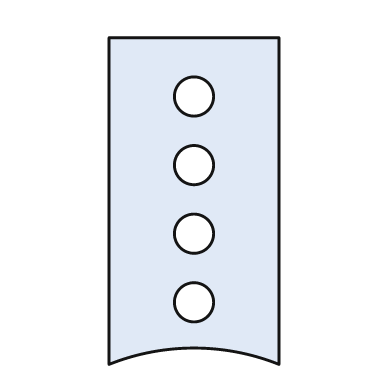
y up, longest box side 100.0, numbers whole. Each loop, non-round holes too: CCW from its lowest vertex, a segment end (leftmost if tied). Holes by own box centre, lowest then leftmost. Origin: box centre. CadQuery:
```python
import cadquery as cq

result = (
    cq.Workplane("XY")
    .moveTo(-26.0, -50.0)
    .threePointArc((0.0, -45.0), (26.0, -50.0))
    .lineTo(26.0, 50.0)
    .lineTo(-26.0, 50.0)
    .close()
    .moveTo(0.0, -31.0)
    .circle(6.0)
    .moveTo(0.0, -10.0)
    .circle(6.0)
    .moveTo(0.0, 11.0)
    .circle(6.0)
    .moveTo(0.0, 32.0)
    .circle(6.0)
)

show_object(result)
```